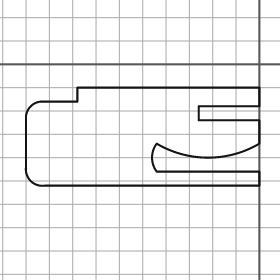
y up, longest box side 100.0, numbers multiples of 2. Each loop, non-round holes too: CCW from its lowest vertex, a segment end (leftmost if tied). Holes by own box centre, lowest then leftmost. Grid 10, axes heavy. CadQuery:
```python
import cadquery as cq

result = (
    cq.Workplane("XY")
    .moveTo(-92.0, -52.0)
    .lineTo(0.0, -52.0)
    .lineTo(0.0, -46.0)
    .lineTo(-44.0, -46.0)
    .threePointArc((-46.0, -40.0), (-44.0, -34.0))
    .threePointArc((-22.0, -40.0), (0.0, -34.0))
    .lineTo(0.0, -24.0)
    .lineTo(-26.0, -24.0)
    .lineTo(-26.0, -18.0)
    .lineTo(0.0, -18.0)
    .lineTo(0.0, -10.0)
    .lineTo(-78.0, -10.0)
    .lineTo(-78.0, -16.0)
    .lineTo(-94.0, -16.0)
    .threePointArc((-98.0, -18.0), (-100.0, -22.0))
    .lineTo(-100.0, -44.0)
    .threePointArc((-98.0, -50.0), (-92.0, -52.0))
    .close()
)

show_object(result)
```